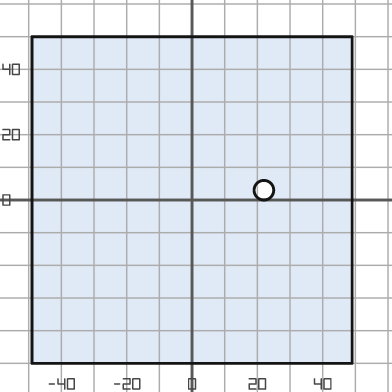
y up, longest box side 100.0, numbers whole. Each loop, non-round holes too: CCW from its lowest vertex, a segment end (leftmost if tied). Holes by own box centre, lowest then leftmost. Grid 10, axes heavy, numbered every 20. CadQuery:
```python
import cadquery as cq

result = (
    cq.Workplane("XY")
    .moveTo(-49.0, -50.0)
    .lineTo(49.0, -50.0)
    .lineTo(49.0, 50.0)
    .lineTo(-49.0, 50.0)
    .close()
    .moveTo(22.0, 3.0)
    .circle(3.0)
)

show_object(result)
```